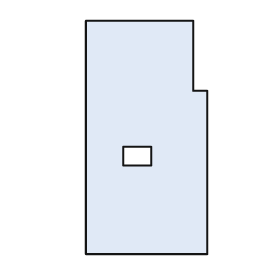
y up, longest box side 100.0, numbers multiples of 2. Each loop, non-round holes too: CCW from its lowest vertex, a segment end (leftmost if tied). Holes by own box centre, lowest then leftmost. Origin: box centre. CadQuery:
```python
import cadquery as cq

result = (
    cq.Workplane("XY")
    .moveTo(-26.0, -50.0)
    .lineTo(26.0, -50.0)
    .lineTo(26.0, 20.0)
    .lineTo(20.0, 20.0)
    .lineTo(20.0, 50.0)
    .lineTo(-26.0, 50.0)
    .close()
    .moveTo(-10.0, -12.0)
    .lineTo(2.0, -12.0)
    .lineTo(2.0, -4.0)
    .lineTo(-10.0, -4.0)
    .close()
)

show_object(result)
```